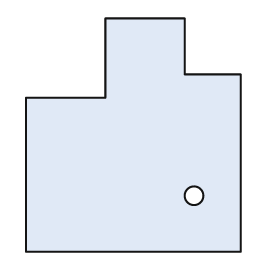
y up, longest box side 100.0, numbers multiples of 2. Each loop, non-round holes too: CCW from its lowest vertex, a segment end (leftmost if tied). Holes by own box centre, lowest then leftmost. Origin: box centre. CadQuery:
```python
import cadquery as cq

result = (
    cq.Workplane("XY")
    .moveTo(-46.0, -50.0)
    .lineTo(46.0, -50.0)
    .lineTo(46.0, 26.0)
    .lineTo(22.0, 26.0)
    .lineTo(22.0, 50.0)
    .lineTo(-12.0, 50.0)
    .lineTo(-12.0, 16.0)
    .lineTo(-46.0, 16.0)
    .close()
    .moveTo(26.0, -26.0)
    .circle(4.0)
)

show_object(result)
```